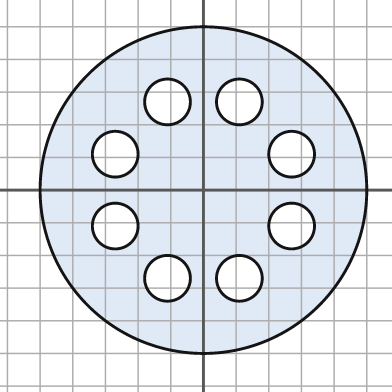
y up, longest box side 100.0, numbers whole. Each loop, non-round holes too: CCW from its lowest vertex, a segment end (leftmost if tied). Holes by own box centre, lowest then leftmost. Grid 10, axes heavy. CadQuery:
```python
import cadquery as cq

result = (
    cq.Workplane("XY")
    .moveTo(0.0, 0.0)
    .circle(50.0)
    .moveTo(-11.0, -27.0)
    .circle(7.0)
    .moveTo(11.0, -27.0)
    .circle(7.0)
    .moveTo(-27.0, -11.0)
    .circle(7.0)
    .moveTo(27.0, -11.0)
    .circle(7.0)
    .moveTo(-27.0, 11.0)
    .circle(7.0)
    .moveTo(27.0, 11.0)
    .circle(7.0)
    .moveTo(-11.0, 27.0)
    .circle(7.0)
    .moveTo(11.0, 27.0)
    .circle(7.0)
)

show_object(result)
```